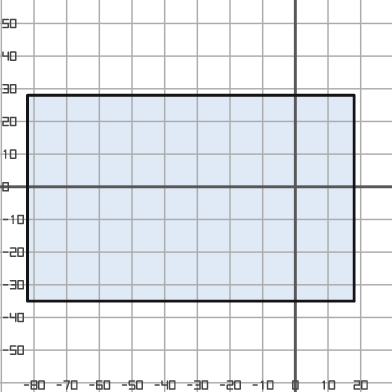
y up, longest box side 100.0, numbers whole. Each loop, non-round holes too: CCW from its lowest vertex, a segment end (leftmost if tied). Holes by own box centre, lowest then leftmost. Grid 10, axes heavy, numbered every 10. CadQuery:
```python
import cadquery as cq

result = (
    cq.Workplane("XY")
    .moveTo(-82.0, -35.0)
    .lineTo(18.0, -35.0)
    .lineTo(18.0, 28.0)
    .lineTo(-82.0, 28.0)
    .close()
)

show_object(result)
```